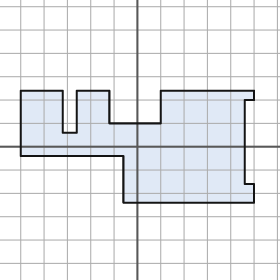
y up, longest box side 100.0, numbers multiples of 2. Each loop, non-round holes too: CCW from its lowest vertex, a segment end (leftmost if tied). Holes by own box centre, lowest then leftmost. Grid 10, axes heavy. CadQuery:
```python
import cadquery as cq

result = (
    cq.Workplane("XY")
    .moveTo(-6.0, -24.0)
    .lineTo(50.0, -24.0)
    .lineTo(50.0, -16.0)
    .lineTo(46.0, -16.0)
    .lineTo(46.0, 20.0)
    .lineTo(50.0, 20.0)
    .lineTo(50.0, 24.0)
    .lineTo(10.0, 24.0)
    .lineTo(10.0, 10.0)
    .lineTo(-12.0, 10.0)
    .lineTo(-12.0, 24.0)
    .lineTo(-26.0, 24.0)
    .lineTo(-26.0, 6.0)
    .lineTo(-32.0, 6.0)
    .lineTo(-32.0, 24.0)
    .lineTo(-50.0, 24.0)
    .lineTo(-50.0, -4.0)
    .lineTo(-6.0, -4.0)
    .close()
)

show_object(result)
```